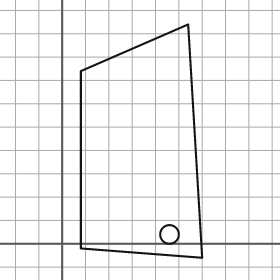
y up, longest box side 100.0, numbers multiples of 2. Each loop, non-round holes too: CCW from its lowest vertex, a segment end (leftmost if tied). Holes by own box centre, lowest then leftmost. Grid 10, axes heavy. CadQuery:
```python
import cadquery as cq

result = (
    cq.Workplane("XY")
    .moveTo(60.0, -6.0)
    .lineTo(54.0, 94.0)
    .lineTo(8.0, 74.0)
    .lineTo(8.0, -2.0)
    .close()
    .moveTo(46.0, 4.0)
    .circle(4.0)
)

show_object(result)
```